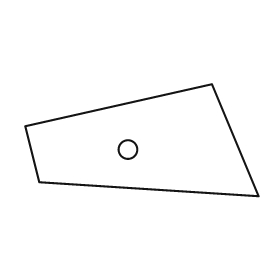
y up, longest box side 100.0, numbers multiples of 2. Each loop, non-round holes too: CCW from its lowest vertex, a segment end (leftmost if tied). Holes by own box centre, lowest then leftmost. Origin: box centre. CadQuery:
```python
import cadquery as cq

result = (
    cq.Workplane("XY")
    .moveTo(50.0, -24.0)
    .lineTo(30.0, 24.0)
    .lineTo(-50.0, 6.0)
    .lineTo(-44.0, -18.0)
    .close()
    .moveTo(-6.0, -4.0)
    .circle(4.0)
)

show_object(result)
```